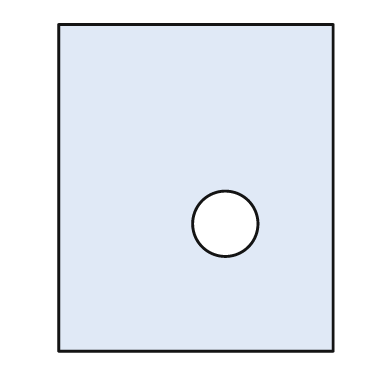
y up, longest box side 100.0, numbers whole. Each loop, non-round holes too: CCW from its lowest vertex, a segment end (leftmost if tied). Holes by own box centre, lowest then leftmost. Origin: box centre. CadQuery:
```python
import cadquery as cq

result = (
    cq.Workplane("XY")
    .moveTo(-42.0, -50.0)
    .lineTo(42.0, -50.0)
    .lineTo(42.0, 50.0)
    .lineTo(-42.0, 50.0)
    .close()
    .moveTo(9.0, -11.0)
    .circle(10.0)
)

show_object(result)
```